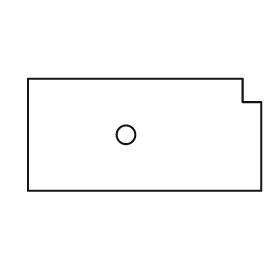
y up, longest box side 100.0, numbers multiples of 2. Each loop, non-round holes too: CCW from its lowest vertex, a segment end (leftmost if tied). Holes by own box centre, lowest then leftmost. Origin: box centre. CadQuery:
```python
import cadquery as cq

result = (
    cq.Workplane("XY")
    .moveTo(-50.0, -24.0)
    .lineTo(50.0, -24.0)
    .lineTo(50.0, 14.0)
    .lineTo(42.0, 14.0)
    .lineTo(42.0, 24.0)
    .lineTo(-50.0, 24.0)
    .close()
    .moveTo(-8.0, 0.0)
    .circle(4.0)
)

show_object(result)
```